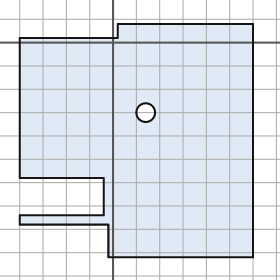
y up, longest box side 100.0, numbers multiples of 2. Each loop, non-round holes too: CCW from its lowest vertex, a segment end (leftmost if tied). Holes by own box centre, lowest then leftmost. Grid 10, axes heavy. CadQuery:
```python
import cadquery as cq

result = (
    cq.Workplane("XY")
    .moveTo(-2.0, -92.0)
    .lineTo(60.0, -92.0)
    .lineTo(60.0, 8.0)
    .lineTo(2.0, 8.0)
    .lineTo(2.0, 2.0)
    .lineTo(-40.0, 2.0)
    .lineTo(-40.0, -58.0)
    .lineTo(-4.0, -58.0)
    .lineTo(-4.0, -74.0)
    .lineTo(-40.0, -74.0)
    .lineTo(-40.0, -78.0)
    .lineTo(-2.0, -78.0)
    .close()
    .moveTo(14.0, -30.0)
    .circle(4.0)
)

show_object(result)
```